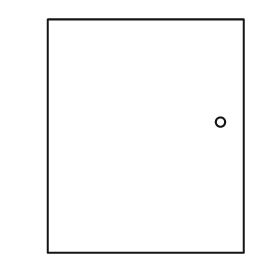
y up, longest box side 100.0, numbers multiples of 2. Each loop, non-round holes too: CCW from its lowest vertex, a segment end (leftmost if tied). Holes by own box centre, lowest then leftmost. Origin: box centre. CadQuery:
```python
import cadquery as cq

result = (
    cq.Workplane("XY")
    .moveTo(-42.0, -50.0)
    .lineTo(42.0, -50.0)
    .lineTo(42.0, 50.0)
    .lineTo(-42.0, 50.0)
    .close()
    .moveTo(32.0, 6.0)
    .circle(2.0)
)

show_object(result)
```